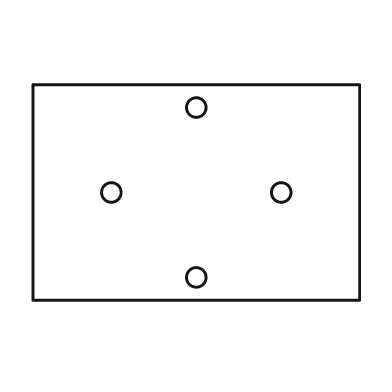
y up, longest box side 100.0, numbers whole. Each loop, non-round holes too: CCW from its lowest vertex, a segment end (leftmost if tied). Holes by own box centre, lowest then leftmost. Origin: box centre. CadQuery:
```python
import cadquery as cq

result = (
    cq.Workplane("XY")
    .moveTo(-50.0, -33.0)
    .lineTo(50.0, -33.0)
    .lineTo(50.0, 33.0)
    .lineTo(-50.0, 33.0)
    .close()
    .moveTo(0.0, -26.0)
    .circle(3.0)
    .moveTo(-26.0, 0.0)
    .circle(3.0)
    .moveTo(26.0, 0.0)
    .circle(3.0)
    .moveTo(0.0, 26.0)
    .circle(3.0)
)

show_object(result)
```